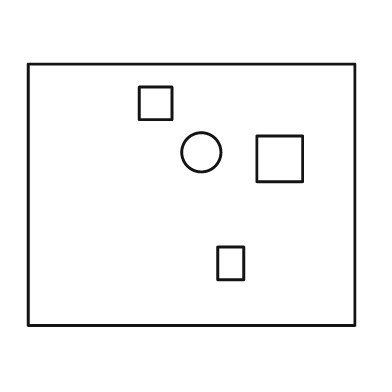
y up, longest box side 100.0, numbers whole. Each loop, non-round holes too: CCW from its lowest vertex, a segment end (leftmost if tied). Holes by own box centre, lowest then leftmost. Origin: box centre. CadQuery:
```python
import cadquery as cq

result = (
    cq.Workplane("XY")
    .moveTo(-50.0, -40.0)
    .lineTo(50.0, -40.0)
    .lineTo(50.0, 40.0)
    .lineTo(-50.0, 40.0)
    .close()
    .moveTo(8.0, -26.0)
    .lineTo(16.0, -26.0)
    .lineTo(16.0, -16.0)
    .lineTo(8.0, -16.0)
    .close()
    .moveTo(20.0, 4.0)
    .lineTo(34.0, 4.0)
    .lineTo(34.0, 18.0)
    .lineTo(20.0, 18.0)
    .close()
    .moveTo(3.0, 13.0)
    .circle(6.0)
    .moveTo(-16.0, 23.0)
    .lineTo(-6.0, 23.0)
    .lineTo(-6.0, 33.0)
    .lineTo(-16.0, 33.0)
    .close()
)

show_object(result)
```